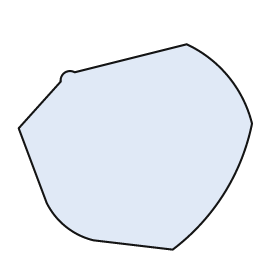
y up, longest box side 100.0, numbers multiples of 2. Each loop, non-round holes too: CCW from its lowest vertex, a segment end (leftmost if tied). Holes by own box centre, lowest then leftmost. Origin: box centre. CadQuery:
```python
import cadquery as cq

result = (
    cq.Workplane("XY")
    .moveTo(16.0, -44.0)
    .threePointArc((38.0, -20.0), (50.0, 10.0))
    .threePointArc((40.0, 30.0), (22.0, 44.0))
    .lineTo(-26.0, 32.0)
    .threePointArc((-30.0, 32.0), (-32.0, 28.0))
    .lineTo(-50.0, 8.0)
    .lineTo(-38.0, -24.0)
    .threePointArc((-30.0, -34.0), (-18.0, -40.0))
    .close()
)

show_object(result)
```